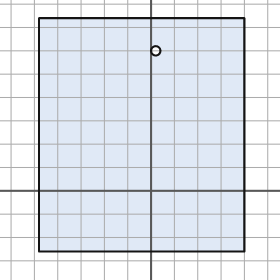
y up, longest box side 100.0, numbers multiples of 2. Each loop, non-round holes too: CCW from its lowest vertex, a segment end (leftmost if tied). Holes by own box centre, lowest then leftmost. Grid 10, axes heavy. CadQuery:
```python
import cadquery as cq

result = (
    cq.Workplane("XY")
    .moveTo(-48.0, -26.0)
    .lineTo(40.0, -26.0)
    .lineTo(40.0, 74.0)
    .lineTo(-48.0, 74.0)
    .close()
    .moveTo(2.0, 60.0)
    .circle(2.0)
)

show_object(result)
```